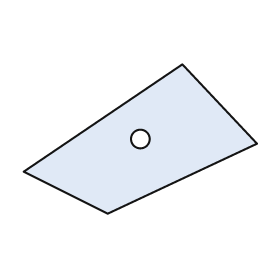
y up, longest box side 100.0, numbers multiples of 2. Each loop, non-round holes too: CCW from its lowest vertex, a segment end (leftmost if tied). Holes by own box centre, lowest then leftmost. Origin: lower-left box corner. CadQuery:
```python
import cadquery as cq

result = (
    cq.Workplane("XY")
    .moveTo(36.0, 0.0)
    .lineTo(100.0, 30.0)
    .lineTo(68.0, 64.0)
    .lineTo(0.0, 18.0)
    .close()
    .moveTo(50.0, 32.0)
    .circle(4.0)
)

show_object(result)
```